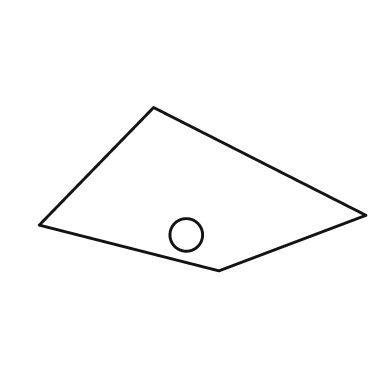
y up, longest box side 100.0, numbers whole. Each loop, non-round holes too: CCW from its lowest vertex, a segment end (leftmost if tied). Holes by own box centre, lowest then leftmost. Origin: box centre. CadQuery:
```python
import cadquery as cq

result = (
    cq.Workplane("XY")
    .moveTo(5.0, -25.0)
    .lineTo(50.0, -8.0)
    .lineTo(-15.0, 25.0)
    .lineTo(-50.0, -11.0)
    .close()
    .moveTo(-5.0, -14.0)
    .circle(5.0)
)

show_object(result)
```